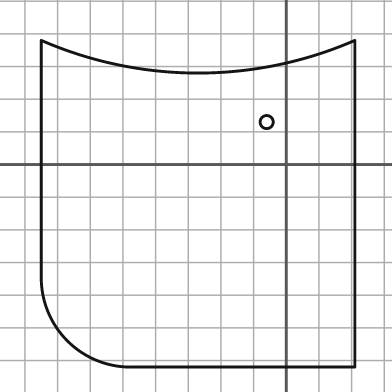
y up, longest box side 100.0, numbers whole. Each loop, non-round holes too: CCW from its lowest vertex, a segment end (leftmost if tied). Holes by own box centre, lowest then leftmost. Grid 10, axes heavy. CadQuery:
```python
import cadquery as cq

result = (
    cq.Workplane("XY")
    .moveTo(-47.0, -62.0)
    .lineTo(21.0, -62.0)
    .lineTo(21.0, 38.0)
    .threePointArc((-27.0, 28.0), (-75.0, 38.0))
    .lineTo(-75.0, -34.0)
    .threePointArc((-67.0, -54.0), (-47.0, -62.0))
    .close()
    .moveTo(-6.0, 13.0)
    .circle(2.0)
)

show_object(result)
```